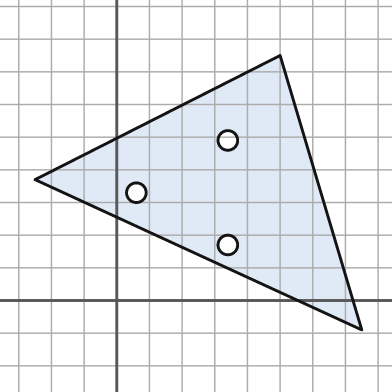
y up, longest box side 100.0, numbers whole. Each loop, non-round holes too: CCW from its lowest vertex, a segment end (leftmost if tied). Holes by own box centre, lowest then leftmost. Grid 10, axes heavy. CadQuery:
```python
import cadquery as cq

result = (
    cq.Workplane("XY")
    .moveTo(75.0, -9.0)
    .lineTo(50.0, 75.0)
    .lineTo(-25.0, 37.0)
    .close()
    .moveTo(34.0, 17.0)
    .circle(3.0)
    .moveTo(6.0, 33.0)
    .circle(3.0)
    .moveTo(34.0, 49.0)
    .circle(3.0)
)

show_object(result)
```